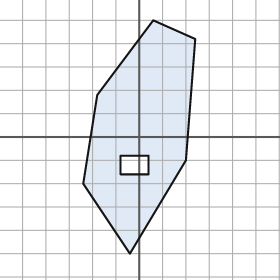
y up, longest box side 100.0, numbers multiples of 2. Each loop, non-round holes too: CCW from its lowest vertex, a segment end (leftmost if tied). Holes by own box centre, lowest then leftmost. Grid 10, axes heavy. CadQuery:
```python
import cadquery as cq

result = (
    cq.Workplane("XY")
    .moveTo(-4.0, -50.0)
    .lineTo(20.0, -10.0)
    .lineTo(24.0, 42.0)
    .lineTo(6.0, 50.0)
    .lineTo(-18.0, 18.0)
    .lineTo(-24.0, -20.0)
    .close()
    .moveTo(-8.0, -16.0)
    .lineTo(4.0, -16.0)
    .lineTo(4.0, -8.0)
    .lineTo(-8.0, -8.0)
    .close()
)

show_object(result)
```